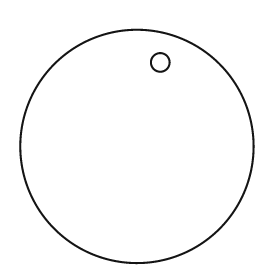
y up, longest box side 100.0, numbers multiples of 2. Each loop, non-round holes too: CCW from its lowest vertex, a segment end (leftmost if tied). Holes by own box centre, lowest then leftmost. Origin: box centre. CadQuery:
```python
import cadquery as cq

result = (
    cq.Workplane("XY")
    .moveTo(0.0, 0.0)
    .circle(50.0)
    .moveTo(10.0, 36.0)
    .circle(4.0)
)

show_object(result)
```